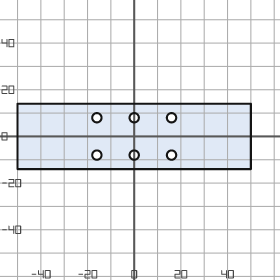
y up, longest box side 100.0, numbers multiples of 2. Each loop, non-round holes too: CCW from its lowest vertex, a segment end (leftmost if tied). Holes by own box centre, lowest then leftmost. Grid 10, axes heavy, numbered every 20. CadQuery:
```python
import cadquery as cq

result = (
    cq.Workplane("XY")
    .moveTo(-50.0, -14.0)
    .lineTo(50.0, -14.0)
    .lineTo(50.0, 14.0)
    .lineTo(-50.0, 14.0)
    .close()
    .moveTo(-16.0, -8.0)
    .circle(2.0)
    .moveTo(0.0, -8.0)
    .circle(2.0)
    .moveTo(16.0, -8.0)
    .circle(2.0)
    .moveTo(-16.0, 8.0)
    .circle(2.0)
    .moveTo(0.0, 8.0)
    .circle(2.0)
    .moveTo(16.0, 8.0)
    .circle(2.0)
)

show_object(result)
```